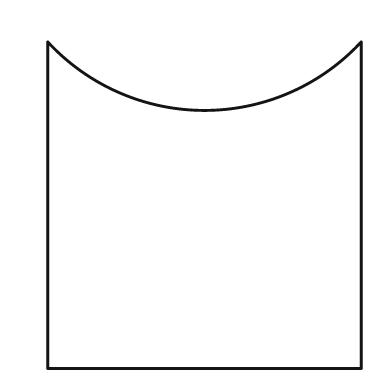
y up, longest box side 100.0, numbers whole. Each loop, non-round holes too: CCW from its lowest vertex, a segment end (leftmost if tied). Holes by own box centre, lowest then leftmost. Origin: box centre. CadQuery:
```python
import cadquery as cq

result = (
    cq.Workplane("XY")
    .moveTo(-48.0, -50.0)
    .lineTo(48.0, -50.0)
    .lineTo(48.0, 50.0)
    .threePointArc((0.0, 29.0), (-48.0, 50.0))
    .close()
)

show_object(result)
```